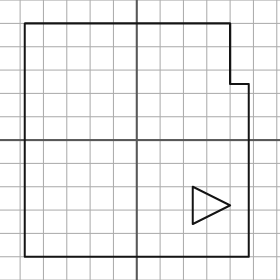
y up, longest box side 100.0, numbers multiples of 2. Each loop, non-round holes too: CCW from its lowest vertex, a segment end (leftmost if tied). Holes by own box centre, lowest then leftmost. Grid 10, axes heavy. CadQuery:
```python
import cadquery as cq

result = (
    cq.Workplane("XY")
    .moveTo(-48.0, -50.0)
    .lineTo(48.0, -50.0)
    .lineTo(48.0, 24.0)
    .lineTo(40.0, 24.0)
    .lineTo(40.0, 50.0)
    .lineTo(-48.0, 50.0)
    .close()
    .moveTo(24.0, -36.0)
    .lineTo(40.0, -28.0)
    .lineTo(24.0, -20.0)
    .close()
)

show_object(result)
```